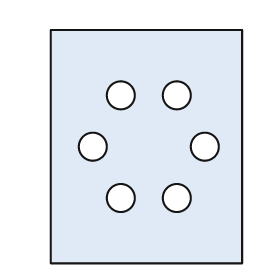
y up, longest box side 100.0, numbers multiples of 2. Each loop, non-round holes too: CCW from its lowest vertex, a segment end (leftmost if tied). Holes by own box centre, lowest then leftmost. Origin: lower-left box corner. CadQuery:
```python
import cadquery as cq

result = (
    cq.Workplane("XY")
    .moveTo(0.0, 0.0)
    .lineTo(82.0, 0.0)
    .lineTo(82.0, 100.0)
    .lineTo(0.0, 100.0)
    .close()
    .moveTo(30.0, 28.0)
    .circle(6.0)
    .moveTo(54.0, 28.0)
    .circle(6.0)
    .moveTo(18.0, 50.0)
    .circle(6.0)
    .moveTo(66.0, 50.0)
    .circle(6.0)
    .moveTo(30.0, 72.0)
    .circle(6.0)
    .moveTo(54.0, 72.0)
    .circle(6.0)
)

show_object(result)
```